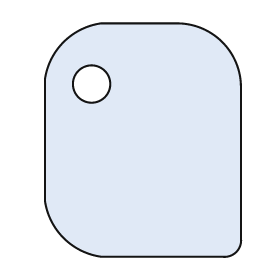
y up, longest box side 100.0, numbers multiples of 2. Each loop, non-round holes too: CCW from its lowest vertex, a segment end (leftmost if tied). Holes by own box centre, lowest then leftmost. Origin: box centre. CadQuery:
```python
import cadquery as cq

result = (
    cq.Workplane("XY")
    .moveTo(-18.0, -50.0)
    .lineTo(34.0, -50.0)
    .threePointArc((40.0, -48.0), (42.0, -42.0))
    .lineTo(42.0, 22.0)
    .threePointArc((34.0, 42.0), (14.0, 50.0))
    .lineTo(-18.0, 50.0)
    .threePointArc((-34.0, 42.0), (-42.0, 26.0))
    .lineTo(-42.0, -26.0)
    .threePointArc((-34.0, -42.0), (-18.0, -50.0))
    .close()
    .moveTo(-22.0, 24.0)
    .circle(8.0)
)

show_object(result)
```